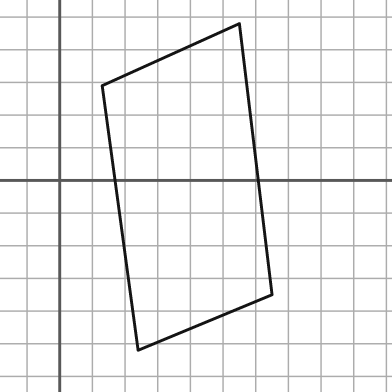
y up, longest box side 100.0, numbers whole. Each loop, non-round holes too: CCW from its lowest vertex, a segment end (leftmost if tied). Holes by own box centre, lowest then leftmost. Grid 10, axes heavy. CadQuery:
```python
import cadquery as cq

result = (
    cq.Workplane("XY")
    .moveTo(24.0, -52.0)
    .lineTo(65.0, -35.0)
    .lineTo(55.0, 48.0)
    .lineTo(13.0, 29.0)
    .close()
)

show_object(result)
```